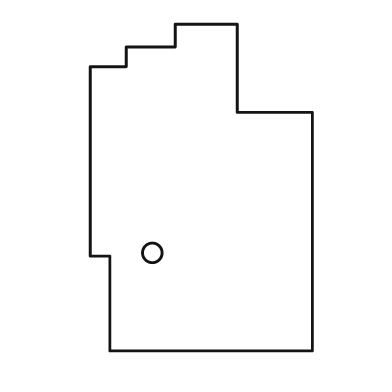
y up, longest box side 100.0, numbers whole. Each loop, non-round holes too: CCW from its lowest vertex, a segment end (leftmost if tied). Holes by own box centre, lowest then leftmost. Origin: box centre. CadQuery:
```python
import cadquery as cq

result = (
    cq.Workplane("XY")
    .moveTo(-28.0, -50.0)
    .lineTo(34.0, -50.0)
    .lineTo(34.0, 23.0)
    .lineTo(11.0, 23.0)
    .lineTo(11.0, 50.0)
    .lineTo(-8.0, 50.0)
    .lineTo(-8.0, 43.0)
    .lineTo(-23.0, 43.0)
    .lineTo(-23.0, 37.0)
    .lineTo(-34.0, 37.0)
    .lineTo(-34.0, -21.0)
    .lineTo(-28.0, -21.0)
    .close()
    .moveTo(-15.0, -20.0)
    .circle(3.0)
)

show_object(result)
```